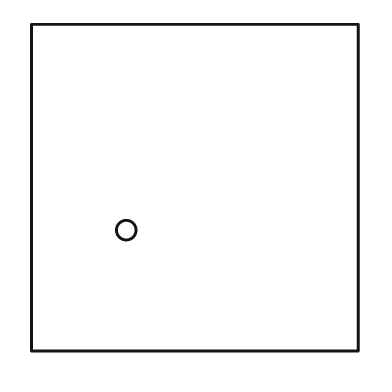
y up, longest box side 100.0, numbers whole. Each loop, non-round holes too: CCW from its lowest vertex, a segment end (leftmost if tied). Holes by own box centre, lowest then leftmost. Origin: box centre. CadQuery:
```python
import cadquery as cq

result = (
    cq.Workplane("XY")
    .moveTo(-50.0, -50.0)
    .lineTo(50.0, -50.0)
    .lineTo(50.0, 50.0)
    .lineTo(-50.0, 50.0)
    .close()
    .moveTo(-21.0, -13.0)
    .circle(3.0)
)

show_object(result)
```